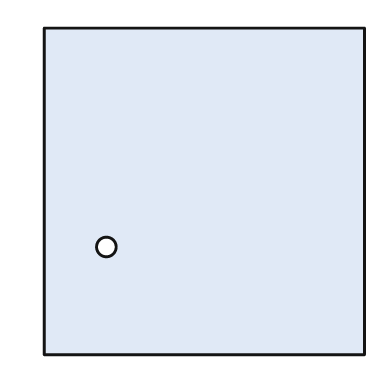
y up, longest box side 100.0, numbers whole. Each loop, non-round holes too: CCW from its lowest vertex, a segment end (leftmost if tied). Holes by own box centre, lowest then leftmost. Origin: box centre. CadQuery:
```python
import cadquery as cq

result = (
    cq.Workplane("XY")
    .moveTo(-49.0, -50.0)
    .lineTo(49.0, -50.0)
    .lineTo(49.0, 50.0)
    .lineTo(-49.0, 50.0)
    .close()
    .moveTo(-30.0, -17.0)
    .circle(3.0)
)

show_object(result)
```